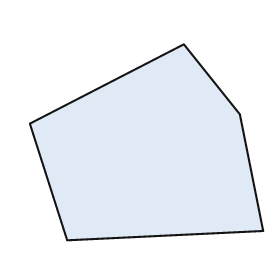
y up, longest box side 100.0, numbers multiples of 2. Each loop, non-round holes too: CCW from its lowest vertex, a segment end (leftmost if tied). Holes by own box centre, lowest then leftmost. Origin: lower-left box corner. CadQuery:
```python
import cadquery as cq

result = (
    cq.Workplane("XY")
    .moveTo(16.0, 0.0)
    .lineTo(100.0, 4.0)
    .lineTo(90.0, 54.0)
    .lineTo(66.0, 84.0)
    .lineTo(0.0, 50.0)
    .close()
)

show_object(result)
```